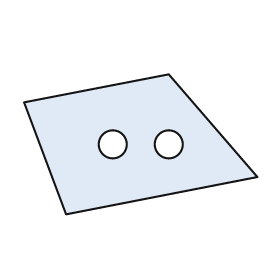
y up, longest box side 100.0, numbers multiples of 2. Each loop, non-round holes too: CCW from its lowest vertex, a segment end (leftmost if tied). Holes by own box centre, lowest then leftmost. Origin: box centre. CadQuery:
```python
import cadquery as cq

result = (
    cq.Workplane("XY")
    .moveTo(-32.0, -30.0)
    .lineTo(50.0, -14.0)
    .lineTo(12.0, 30.0)
    .lineTo(-50.0, 18.0)
    .close()
    .moveTo(-12.0, 0.0)
    .circle(6.0)
    .moveTo(12.0, 0.0)
    .circle(6.0)
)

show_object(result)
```